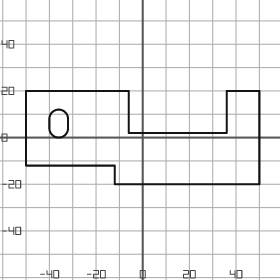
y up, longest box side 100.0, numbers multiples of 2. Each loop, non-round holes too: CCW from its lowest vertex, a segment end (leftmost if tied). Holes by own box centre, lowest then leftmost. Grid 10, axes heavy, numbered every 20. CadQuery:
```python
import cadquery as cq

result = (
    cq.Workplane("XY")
    .moveTo(-12.0, -20.0)
    .lineTo(50.0, -20.0)
    .lineTo(50.0, 20.0)
    .lineTo(36.0, 20.0)
    .lineTo(36.0, 2.0)
    .lineTo(-6.0, 2.0)
    .lineTo(-6.0, 20.0)
    .lineTo(-50.0, 20.0)
    .lineTo(-50.0, -12.0)
    .lineTo(-12.0, -12.0)
    .close()
    .moveTo(-40.0, 4.0)
    .threePointArc((-36.0, 0.0), (-32.0, 4.0))
    .lineTo(-32.0, 8.0)
    .threePointArc((-36.0, 12.0), (-40.0, 8.0))
    .close()
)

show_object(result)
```